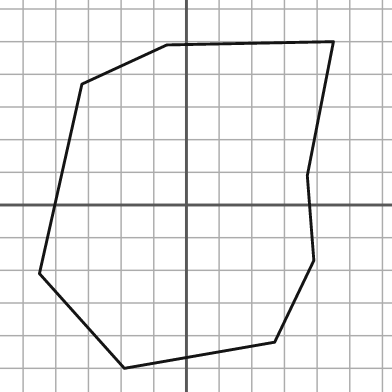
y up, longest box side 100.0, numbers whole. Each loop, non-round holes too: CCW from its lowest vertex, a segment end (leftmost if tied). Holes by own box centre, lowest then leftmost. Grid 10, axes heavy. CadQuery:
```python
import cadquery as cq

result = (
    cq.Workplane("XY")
    .moveTo(-19.0, -50.0)
    .lineTo(27.0, -42.0)
    .lineTo(39.0, -17.0)
    .lineTo(37.0, 9.0)
    .lineTo(45.0, 50.0)
    .lineTo(-6.0, 49.0)
    .lineTo(-32.0, 37.0)
    .lineTo(-45.0, -21.0)
    .close()
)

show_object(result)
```